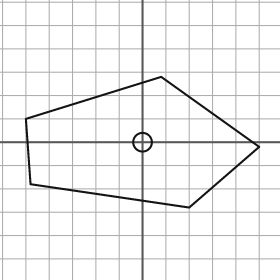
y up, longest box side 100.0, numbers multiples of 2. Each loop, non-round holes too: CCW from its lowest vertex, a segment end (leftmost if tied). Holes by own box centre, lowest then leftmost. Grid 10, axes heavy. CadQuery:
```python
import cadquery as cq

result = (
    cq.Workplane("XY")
    .moveTo(20.0, -28.0)
    .lineTo(50.0, -2.0)
    .lineTo(8.0, 28.0)
    .lineTo(-50.0, 10.0)
    .lineTo(-48.0, -18.0)
    .close()
    .moveTo(0.0, 0.0)
    .circle(4.0)
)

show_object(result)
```